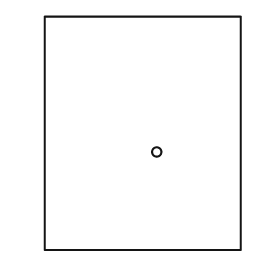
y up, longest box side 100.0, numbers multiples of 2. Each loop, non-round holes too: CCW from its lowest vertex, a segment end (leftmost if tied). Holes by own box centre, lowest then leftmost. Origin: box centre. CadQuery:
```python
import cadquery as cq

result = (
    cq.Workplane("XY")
    .moveTo(-42.0, -50.0)
    .lineTo(42.0, -50.0)
    .lineTo(42.0, 50.0)
    .lineTo(-42.0, 50.0)
    .close()
    .moveTo(6.0, -8.0)
    .circle(2.0)
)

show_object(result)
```